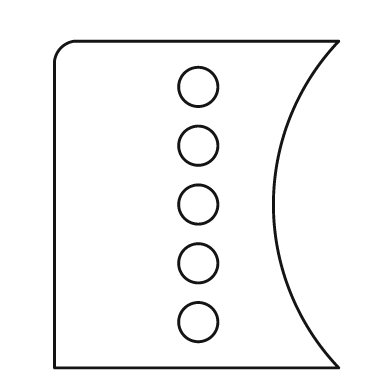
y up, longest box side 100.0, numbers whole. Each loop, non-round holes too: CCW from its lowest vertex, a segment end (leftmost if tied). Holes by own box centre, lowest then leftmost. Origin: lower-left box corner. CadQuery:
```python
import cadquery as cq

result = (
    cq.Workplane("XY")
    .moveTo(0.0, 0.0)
    .lineTo(87.0, 0.0)
    .threePointArc((67.0, 50.0), (87.0, 100.0))
    .lineTo(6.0, 100.0)
    .threePointArc((2.0, 98.0), (0.0, 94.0))
    .close()
    .moveTo(44.0, 14.0)
    .circle(6.0)
    .moveTo(44.0, 32.0)
    .circle(6.0)
    .moveTo(44.0, 50.0)
    .circle(6.0)
    .moveTo(44.0, 68.0)
    .circle(6.0)
    .moveTo(44.0, 86.0)
    .circle(6.0)
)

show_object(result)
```